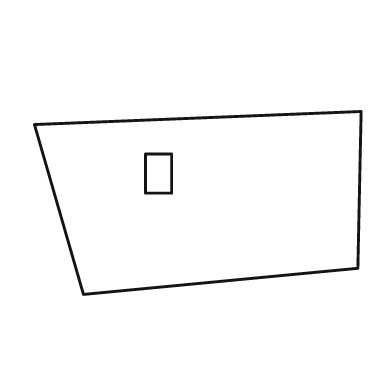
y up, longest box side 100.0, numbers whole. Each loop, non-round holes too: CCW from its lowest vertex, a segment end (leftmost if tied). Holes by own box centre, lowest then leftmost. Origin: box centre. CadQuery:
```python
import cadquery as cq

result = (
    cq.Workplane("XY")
    .moveTo(-35.0, -28.0)
    .lineTo(49.0, -20.0)
    .lineTo(50.0, 28.0)
    .lineTo(-50.0, 24.0)
    .close()
    .moveTo(-16.0, 3.0)
    .lineTo(-8.0, 3.0)
    .lineTo(-8.0, 15.0)
    .lineTo(-16.0, 15.0)
    .close()
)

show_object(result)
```